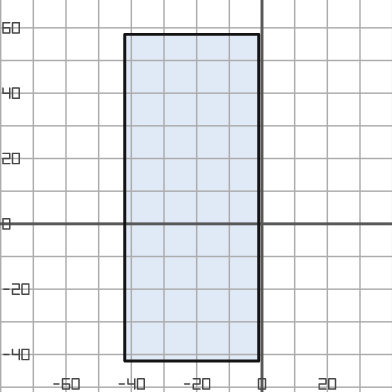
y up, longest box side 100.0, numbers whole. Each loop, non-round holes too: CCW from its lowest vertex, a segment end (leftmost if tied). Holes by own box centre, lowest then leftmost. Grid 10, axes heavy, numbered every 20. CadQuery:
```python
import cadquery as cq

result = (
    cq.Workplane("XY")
    .moveTo(-42.0, -42.0)
    .lineTo(-1.0, -42.0)
    .lineTo(-1.0, 58.0)
    .lineTo(-42.0, 58.0)
    .close()
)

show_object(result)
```